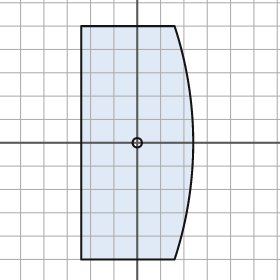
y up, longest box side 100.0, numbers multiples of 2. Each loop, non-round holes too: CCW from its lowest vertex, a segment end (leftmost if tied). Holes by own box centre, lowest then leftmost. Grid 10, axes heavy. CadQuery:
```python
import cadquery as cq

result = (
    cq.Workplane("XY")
    .moveTo(-24.0, -50.0)
    .lineTo(16.0, -50.0)
    .threePointArc((24.0, 0.0), (16.0, 50.0))
    .lineTo(-24.0, 50.0)
    .close()
    .moveTo(0.0, 0.0)
    .circle(2.0)
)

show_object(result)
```